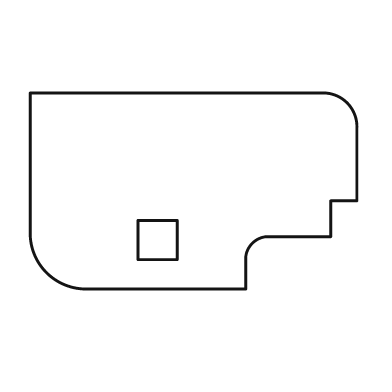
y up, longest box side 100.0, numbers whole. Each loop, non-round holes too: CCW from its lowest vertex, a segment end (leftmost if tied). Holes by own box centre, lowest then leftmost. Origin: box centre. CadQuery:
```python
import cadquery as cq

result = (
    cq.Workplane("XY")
    .moveTo(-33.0, -30.0)
    .lineTo(16.0, -30.0)
    .lineTo(16.0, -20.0)
    .threePointArc((18.0, -16.0), (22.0, -14.0))
    .lineTo(42.0, -14.0)
    .lineTo(42.0, -3.0)
    .lineTo(50.0, -3.0)
    .lineTo(50.0, 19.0)
    .threePointArc((47.0, 27.0), (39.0, 30.0))
    .lineTo(-50.0, 30.0)
    .lineTo(-50.0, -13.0)
    .threePointArc((-45.0, -25.0), (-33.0, -30.0))
    .close()
    .moveTo(-17.0, -21.0)
    .lineTo(-5.0, -21.0)
    .lineTo(-5.0, -9.0)
    .lineTo(-17.0, -9.0)
    .close()
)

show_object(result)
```